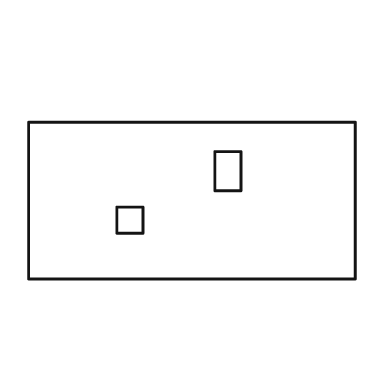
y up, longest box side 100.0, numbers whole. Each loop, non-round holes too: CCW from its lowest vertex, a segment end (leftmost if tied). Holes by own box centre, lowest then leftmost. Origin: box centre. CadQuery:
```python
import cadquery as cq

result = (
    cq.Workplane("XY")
    .moveTo(-50.0, -24.0)
    .lineTo(50.0, -24.0)
    .lineTo(50.0, 24.0)
    .lineTo(-50.0, 24.0)
    .close()
    .moveTo(-23.0, -10.0)
    .lineTo(-15.0, -10.0)
    .lineTo(-15.0, -2.0)
    .lineTo(-23.0, -2.0)
    .close()
    .moveTo(7.0, 3.0)
    .lineTo(15.0, 3.0)
    .lineTo(15.0, 15.0)
    .lineTo(7.0, 15.0)
    .close()
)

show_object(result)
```